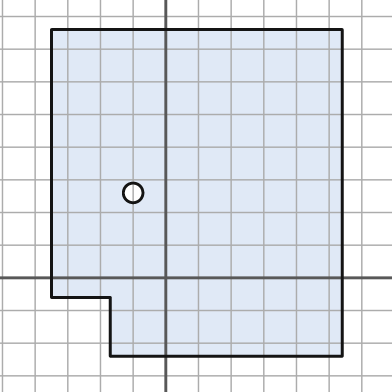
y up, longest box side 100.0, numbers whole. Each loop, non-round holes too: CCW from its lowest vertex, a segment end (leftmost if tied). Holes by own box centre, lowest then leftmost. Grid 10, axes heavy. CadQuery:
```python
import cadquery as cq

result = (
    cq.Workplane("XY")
    .moveTo(-17.0, -24.0)
    .lineTo(54.0, -24.0)
    .lineTo(54.0, 76.0)
    .lineTo(-35.0, 76.0)
    .lineTo(-35.0, -6.0)
    .lineTo(-17.0, -6.0)
    .close()
    .moveTo(-10.0, 26.0)
    .circle(3.0)
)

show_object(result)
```